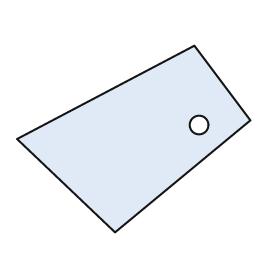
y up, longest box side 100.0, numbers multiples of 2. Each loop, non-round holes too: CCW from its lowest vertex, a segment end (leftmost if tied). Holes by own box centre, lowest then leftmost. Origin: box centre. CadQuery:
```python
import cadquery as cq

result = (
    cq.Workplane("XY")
    .moveTo(-8.0, -40.0)
    .lineTo(50.0, 8.0)
    .lineTo(26.0, 40.0)
    .lineTo(-50.0, 0.0)
    .close()
    .moveTo(28.0, 6.0)
    .circle(4.0)
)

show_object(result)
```